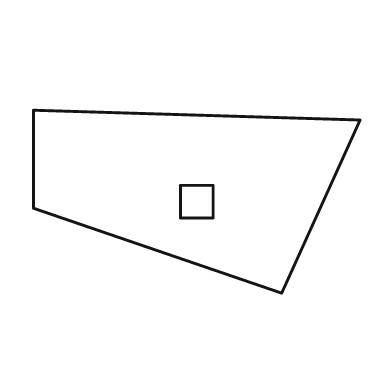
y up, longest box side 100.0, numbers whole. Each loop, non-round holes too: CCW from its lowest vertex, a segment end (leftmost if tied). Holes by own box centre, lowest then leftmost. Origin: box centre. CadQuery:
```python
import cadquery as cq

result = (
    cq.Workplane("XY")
    .moveTo(26.0, -28.0)
    .lineTo(50.0, 25.0)
    .lineTo(-50.0, 28.0)
    .lineTo(-50.0, -2.0)
    .close()
    .moveTo(-5.0, -5.0)
    .lineTo(5.0, -5.0)
    .lineTo(5.0, 5.0)
    .lineTo(-5.0, 5.0)
    .close()
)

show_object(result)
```